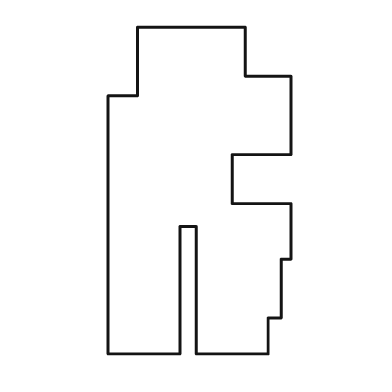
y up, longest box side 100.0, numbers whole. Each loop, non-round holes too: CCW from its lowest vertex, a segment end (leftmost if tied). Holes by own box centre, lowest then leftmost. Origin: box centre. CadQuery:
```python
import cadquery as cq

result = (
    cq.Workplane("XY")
    .moveTo(-28.0, -50.0)
    .lineTo(-6.0, -50.0)
    .lineTo(-6.0, -11.0)
    .lineTo(-1.0, -11.0)
    .lineTo(-1.0, -50.0)
    .lineTo(21.0, -50.0)
    .lineTo(21.0, -39.0)
    .lineTo(25.0, -39.0)
    .lineTo(25.0, -21.0)
    .lineTo(28.0, -21.0)
    .lineTo(28.0, -4.0)
    .lineTo(10.0, -4.0)
    .lineTo(10.0, 11.0)
    .lineTo(28.0, 11.0)
    .lineTo(28.0, 35.0)
    .lineTo(14.0, 35.0)
    .lineTo(14.0, 50.0)
    .lineTo(-19.0, 50.0)
    .lineTo(-19.0, 29.0)
    .lineTo(-28.0, 29.0)
    .close()
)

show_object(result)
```